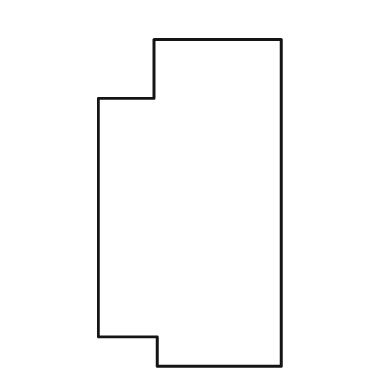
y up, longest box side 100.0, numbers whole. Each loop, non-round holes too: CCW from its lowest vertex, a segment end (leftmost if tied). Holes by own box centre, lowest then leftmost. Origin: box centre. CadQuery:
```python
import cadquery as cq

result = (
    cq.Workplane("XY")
    .moveTo(-10.0, -50.0)
    .lineTo(28.0, -50.0)
    .lineTo(28.0, 50.0)
    .lineTo(-11.0, 50.0)
    .lineTo(-11.0, 32.0)
    .lineTo(-28.0, 32.0)
    .lineTo(-28.0, -41.0)
    .lineTo(-10.0, -41.0)
    .close()
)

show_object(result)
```